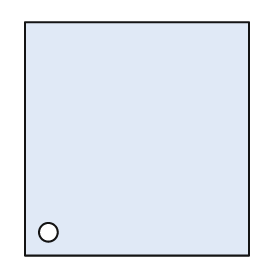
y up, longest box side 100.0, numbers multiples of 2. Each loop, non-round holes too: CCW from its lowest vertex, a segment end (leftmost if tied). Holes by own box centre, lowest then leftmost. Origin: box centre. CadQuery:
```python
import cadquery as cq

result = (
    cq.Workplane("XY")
    .moveTo(-48.0, -50.0)
    .lineTo(48.0, -50.0)
    .lineTo(48.0, 50.0)
    .lineTo(-48.0, 50.0)
    .close()
    .moveTo(-38.0, -40.0)
    .circle(4.0)
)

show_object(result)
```